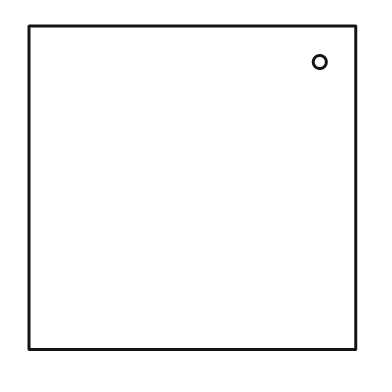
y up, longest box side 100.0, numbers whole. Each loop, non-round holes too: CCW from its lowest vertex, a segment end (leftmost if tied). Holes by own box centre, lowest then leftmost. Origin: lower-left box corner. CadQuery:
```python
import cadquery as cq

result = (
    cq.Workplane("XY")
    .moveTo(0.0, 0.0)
    .lineTo(100.0, 0.0)
    .lineTo(100.0, 99.0)
    .lineTo(0.0, 99.0)
    .close()
    .moveTo(89.0, 88.0)
    .circle(2.0)
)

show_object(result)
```